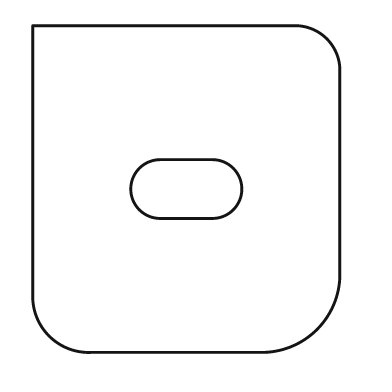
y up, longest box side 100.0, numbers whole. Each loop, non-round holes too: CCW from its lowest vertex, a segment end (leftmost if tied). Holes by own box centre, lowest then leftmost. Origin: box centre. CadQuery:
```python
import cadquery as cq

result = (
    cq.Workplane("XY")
    .moveTo(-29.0, -50.0)
    .lineTo(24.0, -50.0)
    .threePointArc((40.0, -43.0), (47.0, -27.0))
    .lineTo(47.0, 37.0)
    .threePointArc((43.0, 46.0), (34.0, 50.0))
    .lineTo(-47.0, 50.0)
    .lineTo(-47.0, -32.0)
    .threePointArc((-42.0, -45.0), (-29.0, -50.0))
    .close()
    .moveTo(-8.0, -9.0)
    .lineTo(8.0, -9.0)
    .threePointArc((17.0, 0.0), (8.0, 9.0))
    .lineTo(-8.0, 9.0)
    .threePointArc((-17.0, 0.0), (-8.0, -9.0))
    .close()
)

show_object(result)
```